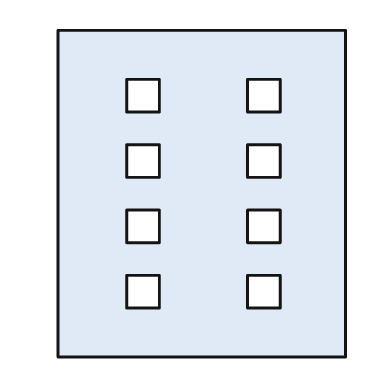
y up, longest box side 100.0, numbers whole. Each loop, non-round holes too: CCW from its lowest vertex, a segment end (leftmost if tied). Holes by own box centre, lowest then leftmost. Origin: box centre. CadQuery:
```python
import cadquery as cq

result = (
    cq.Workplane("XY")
    .moveTo(-44.0, -50.0)
    .lineTo(44.0, -50.0)
    .lineTo(44.0, 50.0)
    .lineTo(-44.0, 50.0)
    .close()
    .moveTo(-23.0, -35.0)
    .lineTo(-13.0, -35.0)
    .lineTo(-13.0, -25.0)
    .lineTo(-23.0, -25.0)
    .close()
    .moveTo(14.0, -35.0)
    .lineTo(24.0, -35.0)
    .lineTo(24.0, -25.0)
    .lineTo(14.0, -25.0)
    .close()
    .moveTo(-23.0, -15.0)
    .lineTo(-13.0, -15.0)
    .lineTo(-13.0, -5.0)
    .lineTo(-23.0, -5.0)
    .close()
    .moveTo(14.0, -15.0)
    .lineTo(24.0, -15.0)
    .lineTo(24.0, -5.0)
    .lineTo(14.0, -5.0)
    .close()
    .moveTo(-23.0, 5.0)
    .lineTo(-13.0, 5.0)
    .lineTo(-13.0, 15.0)
    .lineTo(-23.0, 15.0)
    .close()
    .moveTo(14.0, 5.0)
    .lineTo(24.0, 5.0)
    .lineTo(24.0, 15.0)
    .lineTo(14.0, 15.0)
    .close()
    .moveTo(-23.0, 25.0)
    .lineTo(-13.0, 25.0)
    .lineTo(-13.0, 35.0)
    .lineTo(-23.0, 35.0)
    .close()
    .moveTo(14.0, 25.0)
    .lineTo(24.0, 25.0)
    .lineTo(24.0, 35.0)
    .lineTo(14.0, 35.0)
    .close()
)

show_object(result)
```